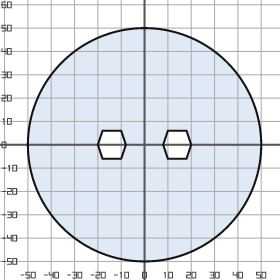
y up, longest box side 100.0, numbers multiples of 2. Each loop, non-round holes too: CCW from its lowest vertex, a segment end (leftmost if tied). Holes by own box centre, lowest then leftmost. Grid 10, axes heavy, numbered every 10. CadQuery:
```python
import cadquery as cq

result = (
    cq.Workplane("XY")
    .moveTo(0.0, 0.0)
    .circle(50.0)
    .moveTo(-18.0, -6.0)
    .lineTo(-10.0, -6.0)
    .lineTo(-8.0, 0.0)
    .lineTo(-10.0, 6.0)
    .lineTo(-18.0, 6.0)
    .lineTo(-20.0, 0.0)
    .close()
    .moveTo(10.0, -6.0)
    .lineTo(18.0, -6.0)
    .lineTo(20.0, 0.0)
    .lineTo(18.0, 6.0)
    .lineTo(10.0, 6.0)
    .lineTo(8.0, 0.0)
    .close()
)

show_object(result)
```